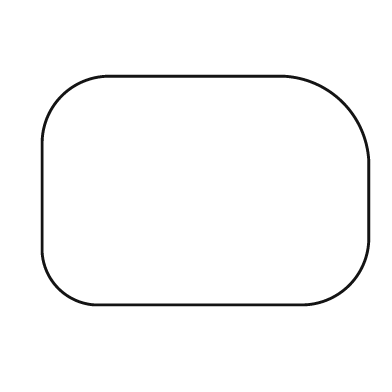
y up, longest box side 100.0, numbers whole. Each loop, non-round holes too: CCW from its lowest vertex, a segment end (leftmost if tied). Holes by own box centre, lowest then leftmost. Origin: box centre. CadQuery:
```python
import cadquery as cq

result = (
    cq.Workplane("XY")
    .moveTo(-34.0, -35.0)
    .lineTo(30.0, -35.0)
    .threePointArc((44.0, -29.0), (50.0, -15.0))
    .lineTo(50.0, 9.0)
    .threePointArc((42.0, 27.0), (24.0, 35.0))
    .lineTo(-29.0, 35.0)
    .threePointArc((-44.0, 29.0), (-50.0, 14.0))
    .lineTo(-50.0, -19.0)
    .threePointArc((-45.0, -30.0), (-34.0, -35.0))
    .close()
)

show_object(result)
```